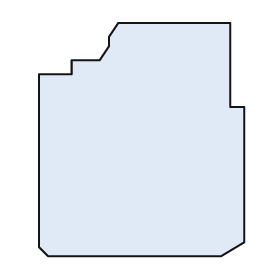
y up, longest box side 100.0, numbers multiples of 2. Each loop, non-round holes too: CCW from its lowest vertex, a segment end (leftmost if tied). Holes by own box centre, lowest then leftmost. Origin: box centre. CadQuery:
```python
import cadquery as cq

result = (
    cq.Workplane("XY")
    .moveTo(-40.0, -50.0)
    .lineTo(34.0, -50.0)
    .lineTo(44.0, -44.0)
    .lineTo(44.0, 14.0)
    .lineTo(38.0, 14.0)
    .lineTo(38.0, 50.0)
    .lineTo(-10.0, 50.0)
    .lineTo(-14.0, 44.0)
    .lineTo(-14.0, 40.0)
    .lineTo(-18.0, 34.0)
    .lineTo(-30.0, 34.0)
    .lineTo(-30.0, 28.0)
    .lineTo(-44.0, 28.0)
    .lineTo(-44.0, -46.0)
    .close()
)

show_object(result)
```